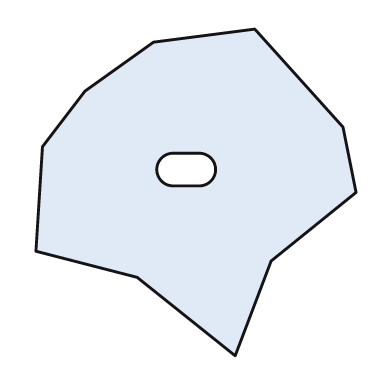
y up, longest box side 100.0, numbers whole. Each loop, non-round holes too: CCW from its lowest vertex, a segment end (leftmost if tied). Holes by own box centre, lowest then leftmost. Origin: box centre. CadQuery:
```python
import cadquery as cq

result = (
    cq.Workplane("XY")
    .moveTo(12.0, -50.0)
    .lineTo(23.0, -21.0)
    .lineTo(49.0, 0.0)
    .lineTo(45.0, 20.0)
    .lineTo(18.0, 50.0)
    .lineTo(-13.0, 46.0)
    .lineTo(-34.0, 31.0)
    .lineTo(-47.0, 14.0)
    .lineTo(-49.0, -18.0)
    .lineTo(-18.0, -26.0)
    .close()
    .moveTo(-7.0, 2.0)
    .lineTo(1.0, 2.0)
    .threePointArc((6.0, 7.0), (1.0, 12.0))
    .lineTo(-7.0, 12.0)
    .threePointArc((-12.0, 7.0), (-7.0, 2.0))
    .close()
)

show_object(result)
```